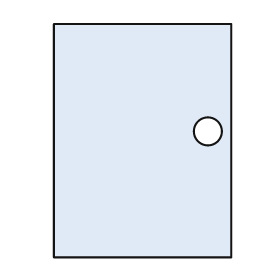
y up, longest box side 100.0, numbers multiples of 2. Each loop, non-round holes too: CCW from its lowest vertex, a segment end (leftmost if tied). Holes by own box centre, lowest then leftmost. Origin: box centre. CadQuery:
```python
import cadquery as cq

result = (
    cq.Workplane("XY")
    .moveTo(-38.0, -50.0)
    .lineTo(38.0, -50.0)
    .lineTo(38.0, 50.0)
    .lineTo(-38.0, 50.0)
    .close()
    .moveTo(28.0, 4.0)
    .circle(6.0)
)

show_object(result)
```